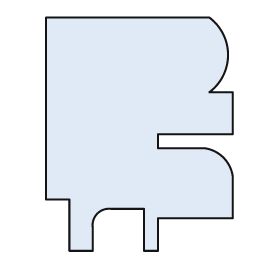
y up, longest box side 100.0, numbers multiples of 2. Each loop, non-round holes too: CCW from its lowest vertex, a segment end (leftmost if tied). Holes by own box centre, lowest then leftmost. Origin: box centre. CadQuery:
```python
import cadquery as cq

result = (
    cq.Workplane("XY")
    .moveTo(-30.0, -50.0)
    .lineTo(-20.0, -50.0)
    .lineTo(-20.0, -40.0)
    .threePointArc((-18.0, -34.0), (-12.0, -32.0))
    .lineTo(2.0, -32.0)
    .lineTo(2.0, -50.0)
    .lineTo(8.0, -50.0)
    .lineTo(8.0, -36.0)
    .lineTo(40.0, -36.0)
    .lineTo(40.0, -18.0)
    .threePointArc((36.0, -10.0), (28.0, -6.0))
    .lineTo(8.0, -6.0)
    .lineTo(8.0, 0.0)
    .lineTo(40.0, 0.0)
    .lineTo(40.0, 18.0)
    .lineTo(30.0, 18.0)
    .threePointArc((38.0, 34.0), (30.0, 50.0))
    .lineTo(-40.0, 50.0)
    .lineTo(-40.0, -28.0)
    .lineTo(-30.0, -28.0)
    .close()
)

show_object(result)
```